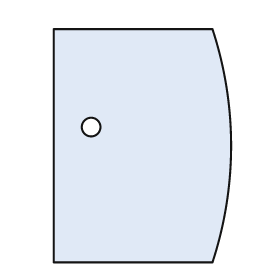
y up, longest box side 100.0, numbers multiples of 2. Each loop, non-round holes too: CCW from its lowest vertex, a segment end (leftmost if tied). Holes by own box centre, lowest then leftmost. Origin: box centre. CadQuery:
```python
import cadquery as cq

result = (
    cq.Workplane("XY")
    .moveTo(-38.0, -50.0)
    .lineTo(30.0, -50.0)
    .threePointArc((38.0, 0.0), (30.0, 50.0))
    .lineTo(-38.0, 50.0)
    .close()
    .moveTo(-22.0, 8.0)
    .circle(4.0)
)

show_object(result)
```